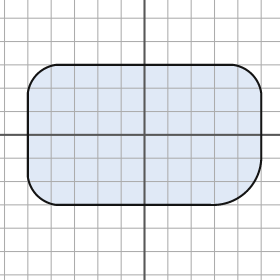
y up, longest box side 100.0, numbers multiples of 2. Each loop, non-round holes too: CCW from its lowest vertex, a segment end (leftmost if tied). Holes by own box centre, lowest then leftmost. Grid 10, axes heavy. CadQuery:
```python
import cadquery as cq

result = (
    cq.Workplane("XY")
    .moveTo(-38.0, -30.0)
    .lineTo(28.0, -30.0)
    .threePointArc((44.0, -24.0), (50.0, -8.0))
    .lineTo(50.0, 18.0)
    .threePointArc((46.0, 26.0), (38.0, 30.0))
    .lineTo(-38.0, 30.0)
    .threePointArc((-46.0, 26.0), (-50.0, 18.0))
    .lineTo(-50.0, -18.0)
    .threePointArc((-46.0, -26.0), (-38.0, -30.0))
    .close()
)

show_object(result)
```